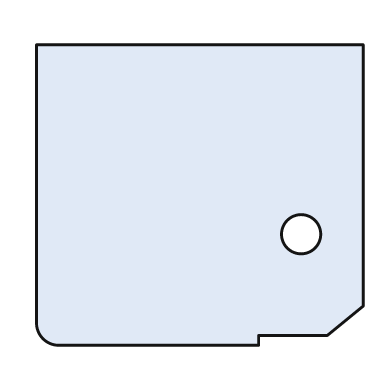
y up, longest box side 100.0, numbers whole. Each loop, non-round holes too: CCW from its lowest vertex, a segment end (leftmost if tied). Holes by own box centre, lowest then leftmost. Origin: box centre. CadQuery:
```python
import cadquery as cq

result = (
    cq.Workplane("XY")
    .moveTo(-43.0, -46.0)
    .lineTo(18.0, -46.0)
    .lineTo(18.0, -43.0)
    .lineTo(39.0, -43.0)
    .lineTo(50.0, -34.0)
    .lineTo(50.0, 46.0)
    .lineTo(-50.0, 46.0)
    .lineTo(-50.0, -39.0)
    .threePointArc((-48.0, -44.0), (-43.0, -46.0))
    .close()
    .moveTo(31.0, -12.0)
    .circle(6.0)
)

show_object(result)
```